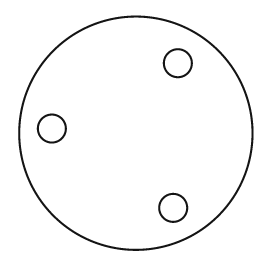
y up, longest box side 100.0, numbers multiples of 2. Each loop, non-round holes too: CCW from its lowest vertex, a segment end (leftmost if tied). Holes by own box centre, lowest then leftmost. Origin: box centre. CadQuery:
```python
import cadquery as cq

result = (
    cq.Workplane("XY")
    .moveTo(0.0, 0.0)
    .circle(50.0)
    .moveTo(16.0, -32.0)
    .circle(6.0)
    .moveTo(-36.0, 2.0)
    .circle(6.0)
    .moveTo(18.0, 30.0)
    .circle(6.0)
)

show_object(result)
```